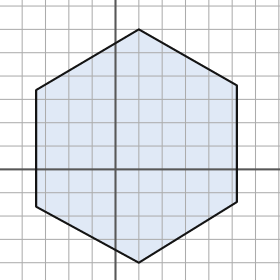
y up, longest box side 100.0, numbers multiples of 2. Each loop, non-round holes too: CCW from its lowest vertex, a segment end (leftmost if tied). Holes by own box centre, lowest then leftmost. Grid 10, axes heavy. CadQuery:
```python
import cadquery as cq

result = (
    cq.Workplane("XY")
    .moveTo(10.0, -40.0)
    .lineTo(52.0, -14.0)
    .lineTo(52.0, 36.0)
    .lineTo(10.0, 60.0)
    .lineTo(-34.0, 34.0)
    .lineTo(-34.0, -16.0)
    .close()
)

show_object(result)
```